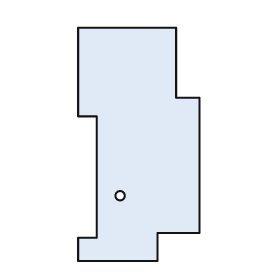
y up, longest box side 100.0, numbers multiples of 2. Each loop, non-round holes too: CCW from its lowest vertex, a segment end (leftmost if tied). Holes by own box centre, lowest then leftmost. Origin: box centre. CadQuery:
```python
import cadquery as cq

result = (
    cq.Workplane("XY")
    .moveTo(-26.0, -50.0)
    .lineTo(8.0, -50.0)
    .lineTo(8.0, -38.0)
    .lineTo(26.0, -38.0)
    .lineTo(26.0, 20.0)
    .lineTo(16.0, 20.0)
    .lineTo(16.0, 50.0)
    .lineTo(-26.0, 50.0)
    .lineTo(-26.0, 12.0)
    .lineTo(-18.0, 12.0)
    .lineTo(-18.0, -40.0)
    .lineTo(-26.0, -40.0)
    .close()
    .moveTo(-8.0, -22.0)
    .circle(2.0)
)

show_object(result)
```